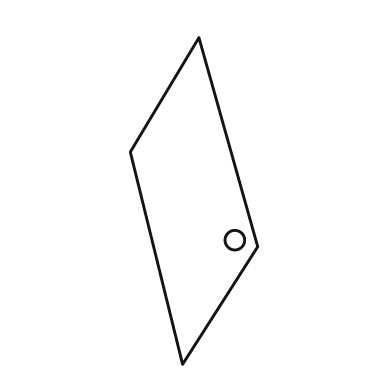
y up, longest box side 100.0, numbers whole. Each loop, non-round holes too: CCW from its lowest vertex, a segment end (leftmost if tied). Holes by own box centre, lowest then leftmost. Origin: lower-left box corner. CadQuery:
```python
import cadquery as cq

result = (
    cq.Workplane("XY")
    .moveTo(16.0, 0.0)
    .lineTo(39.0, 36.0)
    .lineTo(21.0, 100.0)
    .lineTo(0.0, 65.0)
    .close()
    .moveTo(32.0, 38.0)
    .circle(3.0)
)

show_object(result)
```